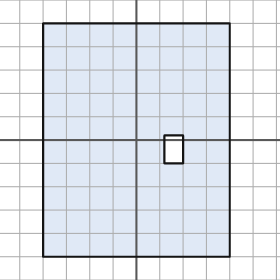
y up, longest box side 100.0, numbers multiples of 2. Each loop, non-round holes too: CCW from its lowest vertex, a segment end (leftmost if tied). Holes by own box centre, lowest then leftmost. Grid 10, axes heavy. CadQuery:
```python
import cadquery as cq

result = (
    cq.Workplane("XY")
    .moveTo(-40.0, -50.0)
    .lineTo(40.0, -50.0)
    .lineTo(40.0, 50.0)
    .lineTo(-40.0, 50.0)
    .close()
    .moveTo(12.0, -10.0)
    .lineTo(20.0, -10.0)
    .lineTo(20.0, 2.0)
    .lineTo(12.0, 2.0)
    .close()
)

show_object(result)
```